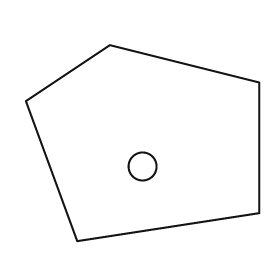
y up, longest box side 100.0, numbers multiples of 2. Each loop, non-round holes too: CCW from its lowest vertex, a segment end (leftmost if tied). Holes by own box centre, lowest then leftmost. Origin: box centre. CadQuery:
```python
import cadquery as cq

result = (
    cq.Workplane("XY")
    .moveTo(-28.0, -42.0)
    .lineTo(50.0, -30.0)
    .lineTo(50.0, 26.0)
    .lineTo(-14.0, 42.0)
    .lineTo(-50.0, 18.0)
    .close()
    .moveTo(0.0, -10.0)
    .circle(6.0)
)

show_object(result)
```